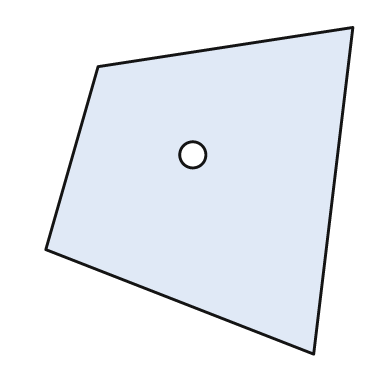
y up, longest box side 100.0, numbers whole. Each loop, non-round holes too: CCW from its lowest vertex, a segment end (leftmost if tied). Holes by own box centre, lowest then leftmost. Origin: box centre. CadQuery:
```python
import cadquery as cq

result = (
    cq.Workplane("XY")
    .moveTo(35.0, -50.0)
    .lineTo(47.0, 50.0)
    .lineTo(-31.0, 38.0)
    .lineTo(-47.0, -18.0)
    .close()
    .moveTo(-2.0, 11.0)
    .circle(4.0)
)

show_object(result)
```